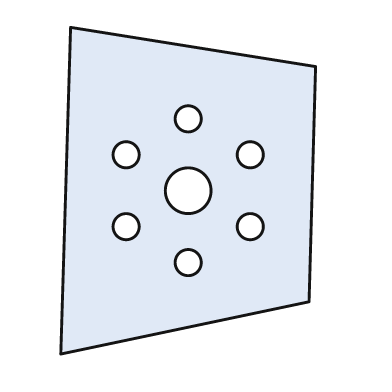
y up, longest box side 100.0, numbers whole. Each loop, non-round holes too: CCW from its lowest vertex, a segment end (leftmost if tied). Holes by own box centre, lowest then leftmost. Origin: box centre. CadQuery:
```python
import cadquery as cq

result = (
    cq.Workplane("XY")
    .moveTo(-39.0, -50.0)
    .lineTo(37.0, -34.0)
    .lineTo(39.0, 38.0)
    .lineTo(-36.0, 50.0)
    .close()
    .moveTo(0.0, -22.0)
    .circle(4.0)
    .moveTo(-19.0, -11.0)
    .circle(4.0)
    .moveTo(19.0, -11.0)
    .circle(4.0)
    .moveTo(0.0, 0.0)
    .circle(7.0)
    .moveTo(-19.0, 11.0)
    .circle(4.0)
    .moveTo(19.0, 11.0)
    .circle(4.0)
    .moveTo(0.0, 22.0)
    .circle(4.0)
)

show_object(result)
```